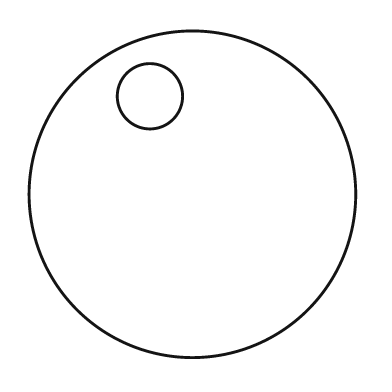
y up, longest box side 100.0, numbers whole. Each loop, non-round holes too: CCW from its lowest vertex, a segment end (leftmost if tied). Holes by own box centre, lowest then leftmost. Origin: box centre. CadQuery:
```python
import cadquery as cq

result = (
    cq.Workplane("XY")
    .moveTo(0.0, 0.0)
    .circle(50.0)
    .moveTo(-13.0, 30.0)
    .circle(10.0)
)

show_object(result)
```